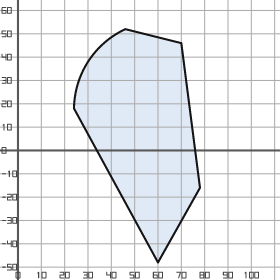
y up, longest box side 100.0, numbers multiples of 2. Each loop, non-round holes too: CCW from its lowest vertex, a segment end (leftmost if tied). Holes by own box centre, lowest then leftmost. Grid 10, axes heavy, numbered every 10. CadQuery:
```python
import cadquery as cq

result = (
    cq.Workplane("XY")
    .moveTo(60.0, -48.0)
    .lineTo(78.0, -16.0)
    .lineTo(70.0, 46.0)
    .lineTo(46.0, 52.0)
    .threePointArc((30.0, 38.0), (24.0, 18.0))
    .close()
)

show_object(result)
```